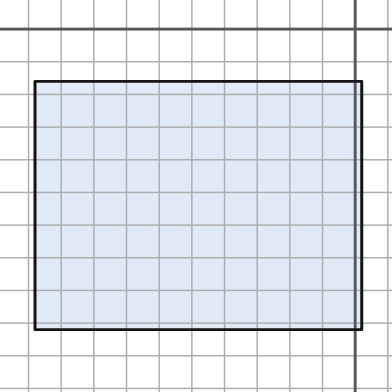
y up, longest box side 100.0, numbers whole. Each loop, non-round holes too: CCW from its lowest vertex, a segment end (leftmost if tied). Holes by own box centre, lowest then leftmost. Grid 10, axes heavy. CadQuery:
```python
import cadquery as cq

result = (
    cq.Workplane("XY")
    .moveTo(-98.0, -92.0)
    .lineTo(2.0, -92.0)
    .lineTo(2.0, -16.0)
    .lineTo(-98.0, -16.0)
    .close()
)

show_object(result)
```